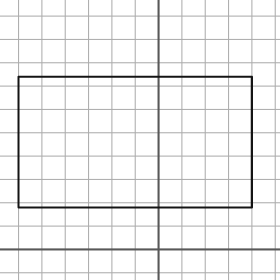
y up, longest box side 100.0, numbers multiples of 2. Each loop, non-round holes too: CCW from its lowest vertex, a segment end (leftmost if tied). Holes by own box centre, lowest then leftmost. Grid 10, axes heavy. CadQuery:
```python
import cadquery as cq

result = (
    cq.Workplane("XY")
    .moveTo(-60.0, 18.0)
    .lineTo(40.0, 18.0)
    .lineTo(40.0, 74.0)
    .lineTo(-60.0, 74.0)
    .close()
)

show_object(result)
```